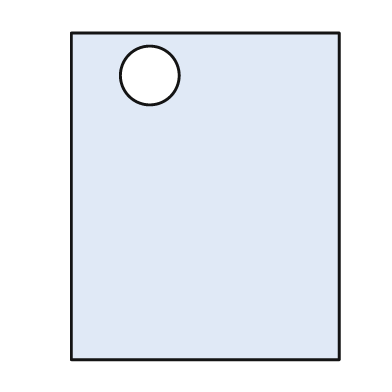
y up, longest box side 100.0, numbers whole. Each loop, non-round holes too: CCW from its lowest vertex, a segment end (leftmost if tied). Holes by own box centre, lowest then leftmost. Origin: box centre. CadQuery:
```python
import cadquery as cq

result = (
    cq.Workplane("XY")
    .moveTo(-41.0, -50.0)
    .lineTo(41.0, -50.0)
    .lineTo(41.0, 50.0)
    .lineTo(-41.0, 50.0)
    .close()
    .moveTo(-17.0, 37.0)
    .circle(9.0)
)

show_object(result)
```